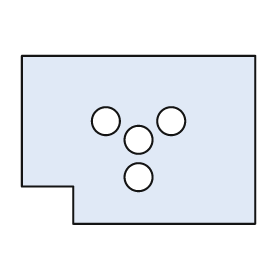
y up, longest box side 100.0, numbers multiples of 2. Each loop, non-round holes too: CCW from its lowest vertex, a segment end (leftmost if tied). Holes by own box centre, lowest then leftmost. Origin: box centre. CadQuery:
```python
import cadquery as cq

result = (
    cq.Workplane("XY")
    .moveTo(-28.0, -36.0)
    .lineTo(50.0, -36.0)
    .lineTo(50.0, 36.0)
    .lineTo(-50.0, 36.0)
    .lineTo(-50.0, -20.0)
    .lineTo(-28.0, -20.0)
    .close()
    .moveTo(0.0, -16.0)
    .circle(6.0)
    .moveTo(0.0, 0.0)
    .circle(6.0)
    .moveTo(-14.0, 8.0)
    .circle(6.0)
    .moveTo(14.0, 8.0)
    .circle(6.0)
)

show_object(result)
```